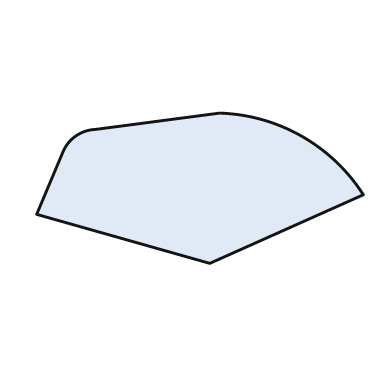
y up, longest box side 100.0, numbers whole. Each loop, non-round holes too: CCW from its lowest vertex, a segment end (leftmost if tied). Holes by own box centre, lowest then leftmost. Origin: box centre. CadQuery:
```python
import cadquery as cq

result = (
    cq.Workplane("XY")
    .moveTo(3.0, -23.0)
    .lineTo(50.0, -2.0)
    .threePointArc((31.0, 16.0), (6.0, 23.0))
    .lineTo(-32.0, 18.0)
    .threePointArc((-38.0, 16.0), (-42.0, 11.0))
    .lineTo(-50.0, -8.0)
    .close()
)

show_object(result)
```